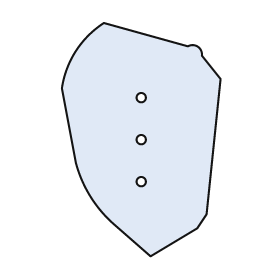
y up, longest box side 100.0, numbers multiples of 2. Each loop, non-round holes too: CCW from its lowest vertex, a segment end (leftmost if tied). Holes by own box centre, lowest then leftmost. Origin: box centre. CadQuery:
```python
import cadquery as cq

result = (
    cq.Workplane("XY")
    .moveTo(4.0, -50.0)
    .lineTo(24.0, -38.0)
    .lineTo(28.0, -32.0)
    .lineTo(34.0, 26.0)
    .lineTo(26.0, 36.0)
    .threePointArc((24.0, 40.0), (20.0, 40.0))
    .lineTo(-16.0, 50.0)
    .threePointArc((-28.0, 38.0), (-34.0, 22.0))
    .lineTo(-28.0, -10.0)
    .threePointArc((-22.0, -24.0), (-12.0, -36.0))
    .close()
    .moveTo(0.0, -18.0)
    .circle(2.0)
    .moveTo(0.0, 0.0)
    .circle(2.0)
    .moveTo(0.0, 18.0)
    .circle(2.0)
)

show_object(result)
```